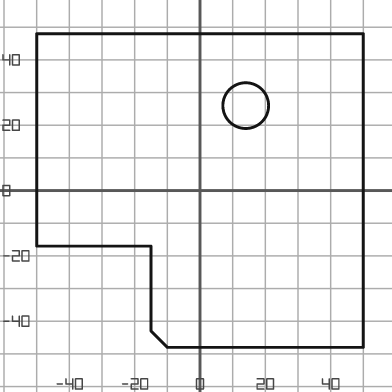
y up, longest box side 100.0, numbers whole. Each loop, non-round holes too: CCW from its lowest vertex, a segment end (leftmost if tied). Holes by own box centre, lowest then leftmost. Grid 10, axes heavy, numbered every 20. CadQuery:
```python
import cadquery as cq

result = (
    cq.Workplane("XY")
    .moveTo(-10.0, -48.0)
    .lineTo(50.0, -48.0)
    .lineTo(50.0, 48.0)
    .lineTo(-50.0, 48.0)
    .lineTo(-50.0, -17.0)
    .lineTo(-15.0, -17.0)
    .lineTo(-15.0, -43.0)
    .close()
    .moveTo(14.0, 26.0)
    .circle(7.0)
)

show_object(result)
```